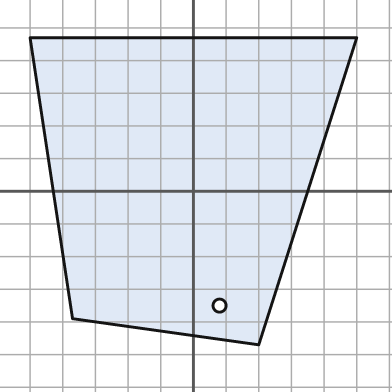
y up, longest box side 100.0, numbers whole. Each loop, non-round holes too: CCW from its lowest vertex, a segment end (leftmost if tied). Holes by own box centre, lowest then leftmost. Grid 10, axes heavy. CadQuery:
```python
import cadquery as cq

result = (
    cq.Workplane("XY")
    .moveTo(20.0, -47.0)
    .lineTo(50.0, 47.0)
    .lineTo(-50.0, 47.0)
    .lineTo(-37.0, -39.0)
    .close()
    .moveTo(8.0, -35.0)
    .circle(2.0)
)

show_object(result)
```